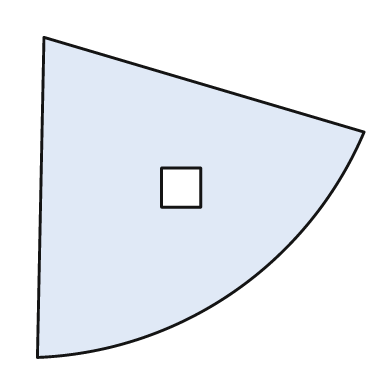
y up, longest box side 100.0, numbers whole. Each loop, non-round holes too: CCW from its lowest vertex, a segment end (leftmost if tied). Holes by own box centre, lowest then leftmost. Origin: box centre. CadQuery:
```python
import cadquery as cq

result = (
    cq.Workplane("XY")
    .moveTo(-50.0, -49.0)
    .threePointArc((10.0, -29.0), (50.0, 20.0))
    .lineTo(-48.0, 49.0)
    .close()
    .moveTo(-12.0, -3.0)
    .lineTo(0.0, -3.0)
    .lineTo(0.0, 9.0)
    .lineTo(-12.0, 9.0)
    .close()
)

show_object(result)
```